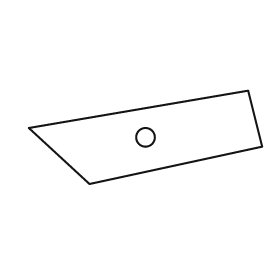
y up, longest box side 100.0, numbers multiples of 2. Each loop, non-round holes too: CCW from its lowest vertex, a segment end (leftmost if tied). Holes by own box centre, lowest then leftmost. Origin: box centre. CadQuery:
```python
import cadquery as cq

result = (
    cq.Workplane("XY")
    .moveTo(-24.0, -20.0)
    .lineTo(50.0, -4.0)
    .lineTo(44.0, 20.0)
    .lineTo(-50.0, 4.0)
    .close()
    .moveTo(0.0, 0.0)
    .circle(4.0)
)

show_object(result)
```